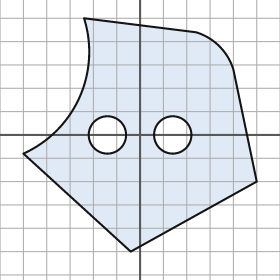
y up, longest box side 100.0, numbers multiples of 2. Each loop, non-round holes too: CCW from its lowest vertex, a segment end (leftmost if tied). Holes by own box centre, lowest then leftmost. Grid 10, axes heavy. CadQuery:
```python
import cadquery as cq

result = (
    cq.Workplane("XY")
    .moveTo(-4.0, -50.0)
    .lineTo(50.0, -20.0)
    .lineTo(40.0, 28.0)
    .threePointArc((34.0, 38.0), (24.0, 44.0))
    .lineTo(-24.0, 50.0)
    .threePointArc((-26.0, 16.0), (-50.0, -8.0))
    .close()
    .moveTo(-14.0, 0.0)
    .circle(8.0)
    .moveTo(14.0, 0.0)
    .circle(8.0)
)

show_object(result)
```